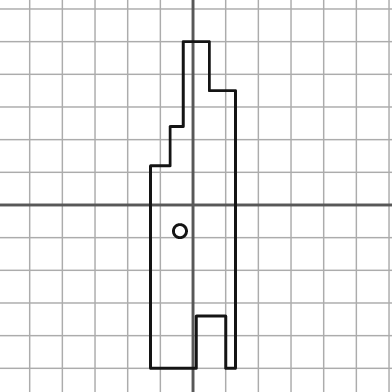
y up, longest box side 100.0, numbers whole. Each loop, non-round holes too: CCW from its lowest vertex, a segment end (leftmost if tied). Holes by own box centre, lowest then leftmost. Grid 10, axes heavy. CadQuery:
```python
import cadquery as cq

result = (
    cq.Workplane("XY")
    .moveTo(-13.0, -50.0)
    .lineTo(1.0, -50.0)
    .lineTo(1.0, -34.0)
    .lineTo(10.0, -34.0)
    .lineTo(10.0, -50.0)
    .lineTo(13.0, -50.0)
    .lineTo(13.0, 35.0)
    .lineTo(5.0, 35.0)
    .lineTo(5.0, 50.0)
    .lineTo(-3.0, 50.0)
    .lineTo(-3.0, 24.0)
    .lineTo(-7.0, 24.0)
    .lineTo(-7.0, 12.0)
    .lineTo(-13.0, 12.0)
    .close()
    .moveTo(-4.0, -8.0)
    .circle(2.0)
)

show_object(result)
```